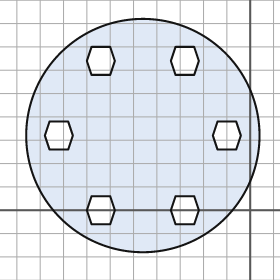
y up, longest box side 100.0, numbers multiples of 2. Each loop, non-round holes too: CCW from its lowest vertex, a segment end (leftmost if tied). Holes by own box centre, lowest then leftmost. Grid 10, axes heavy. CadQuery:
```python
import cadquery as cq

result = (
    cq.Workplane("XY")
    .moveTo(-46.0, 32.0)
    .circle(50.0)
    .moveTo(-68.0, -6.0)
    .lineTo(-60.0, -6.0)
    .lineTo(-58.0, 0.0)
    .lineTo(-60.0, 6.0)
    .lineTo(-68.0, 6.0)
    .lineTo(-70.0, 0.0)
    .close()
    .moveTo(-32.0, -6.0)
    .lineTo(-24.0, -6.0)
    .lineTo(-22.0, 0.0)
    .lineTo(-24.0, 6.0)
    .lineTo(-32.0, 6.0)
    .lineTo(-34.0, 0.0)
    .close()
    .moveTo(-86.0, 26.0)
    .lineTo(-78.0, 26.0)
    .lineTo(-76.0, 32.0)
    .lineTo(-78.0, 38.0)
    .lineTo(-86.0, 38.0)
    .lineTo(-88.0, 32.0)
    .close()
    .moveTo(-14.0, 26.0)
    .lineTo(-6.0, 26.0)
    .lineTo(-4.0, 32.0)
    .lineTo(-6.0, 38.0)
    .lineTo(-14.0, 38.0)
    .lineTo(-16.0, 32.0)
    .close()
    .moveTo(-68.0, 58.0)
    .lineTo(-60.0, 58.0)
    .lineTo(-58.0, 64.0)
    .lineTo(-60.0, 70.0)
    .lineTo(-68.0, 70.0)
    .lineTo(-70.0, 64.0)
    .close()
    .moveTo(-32.0, 58.0)
    .lineTo(-24.0, 58.0)
    .lineTo(-22.0, 64.0)
    .lineTo(-24.0, 70.0)
    .lineTo(-32.0, 70.0)
    .lineTo(-34.0, 64.0)
    .close()
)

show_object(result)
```